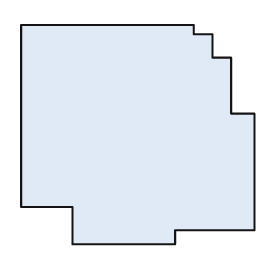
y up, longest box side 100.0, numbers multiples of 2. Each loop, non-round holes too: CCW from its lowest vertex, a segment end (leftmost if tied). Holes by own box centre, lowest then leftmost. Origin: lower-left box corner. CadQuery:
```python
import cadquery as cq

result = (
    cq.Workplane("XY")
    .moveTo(22.0, 0.0)
    .lineTo(66.0, 0.0)
    .lineTo(66.0, 6.0)
    .lineTo(100.0, 6.0)
    .lineTo(100.0, 56.0)
    .lineTo(90.0, 56.0)
    .lineTo(90.0, 80.0)
    .lineTo(82.0, 80.0)
    .lineTo(82.0, 90.0)
    .lineTo(74.0, 90.0)
    .lineTo(74.0, 94.0)
    .lineTo(0.0, 94.0)
    .lineTo(0.0, 16.0)
    .lineTo(22.0, 16.0)
    .close()
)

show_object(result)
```